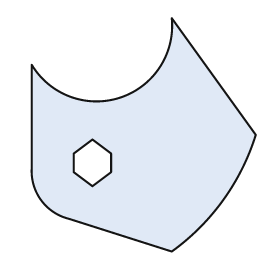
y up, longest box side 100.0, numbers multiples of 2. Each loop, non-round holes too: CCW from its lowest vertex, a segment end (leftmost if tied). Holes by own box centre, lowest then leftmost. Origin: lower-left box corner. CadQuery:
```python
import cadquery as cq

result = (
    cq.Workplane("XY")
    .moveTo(60.0, 0.0)
    .threePointArc((82.0, 22.0), (96.0, 50.0))
    .lineTo(60.0, 100.0)
    .threePointArc((38.0, 66.0), (0.0, 80.0))
    .lineTo(0.0, 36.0)
    .threePointArc((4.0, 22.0), (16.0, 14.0))
    .close()
    .moveTo(26.0, 28.0)
    .lineTo(34.0, 34.0)
    .lineTo(34.0, 42.0)
    .lineTo(26.0, 48.0)
    .lineTo(18.0, 42.0)
    .lineTo(18.0, 34.0)
    .close()
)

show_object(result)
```